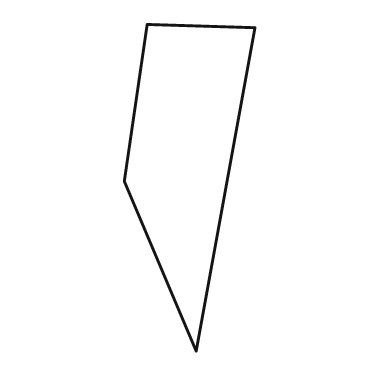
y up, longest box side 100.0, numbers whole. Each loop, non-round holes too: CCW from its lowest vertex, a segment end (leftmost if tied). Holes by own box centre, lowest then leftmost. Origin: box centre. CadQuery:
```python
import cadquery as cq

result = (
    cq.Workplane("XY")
    .moveTo(2.0, -50.0)
    .lineTo(20.0, 49.0)
    .lineTo(-13.0, 50.0)
    .lineTo(-20.0, 2.0)
    .close()
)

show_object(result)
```